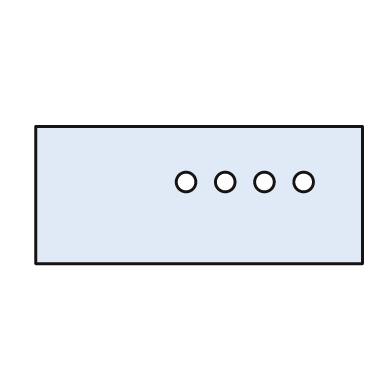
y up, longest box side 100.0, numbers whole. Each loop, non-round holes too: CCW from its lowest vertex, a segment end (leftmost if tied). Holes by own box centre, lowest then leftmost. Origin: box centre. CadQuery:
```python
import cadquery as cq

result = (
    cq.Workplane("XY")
    .moveTo(-50.0, -21.0)
    .lineTo(50.0, -21.0)
    .lineTo(50.0, 21.0)
    .lineTo(-50.0, 21.0)
    .close()
    .moveTo(-4.0, 4.0)
    .circle(3.0)
    .moveTo(8.0, 4.0)
    .circle(3.0)
    .moveTo(20.0, 4.0)
    .circle(3.0)
    .moveTo(32.0, 4.0)
    .circle(3.0)
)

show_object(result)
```